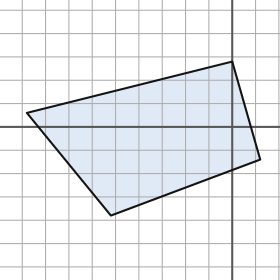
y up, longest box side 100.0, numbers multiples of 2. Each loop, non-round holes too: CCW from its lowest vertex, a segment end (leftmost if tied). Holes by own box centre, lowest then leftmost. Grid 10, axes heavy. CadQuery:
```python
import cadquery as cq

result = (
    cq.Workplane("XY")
    .moveTo(-52.0, -38.0)
    .lineTo(12.0, -14.0)
    .lineTo(0.0, 28.0)
    .lineTo(-88.0, 6.0)
    .close()
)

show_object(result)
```